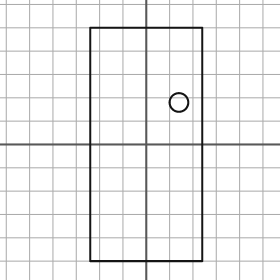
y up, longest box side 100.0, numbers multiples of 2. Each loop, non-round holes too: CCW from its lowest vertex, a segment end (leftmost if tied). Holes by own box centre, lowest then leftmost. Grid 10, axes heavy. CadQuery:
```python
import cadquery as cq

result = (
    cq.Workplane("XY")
    .moveTo(-24.0, -50.0)
    .lineTo(24.0, -50.0)
    .lineTo(24.0, 50.0)
    .lineTo(-24.0, 50.0)
    .close()
    .moveTo(14.0, 18.0)
    .circle(4.0)
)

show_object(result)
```